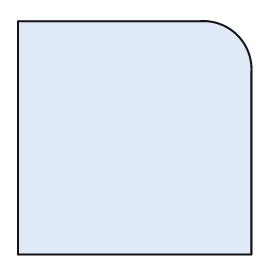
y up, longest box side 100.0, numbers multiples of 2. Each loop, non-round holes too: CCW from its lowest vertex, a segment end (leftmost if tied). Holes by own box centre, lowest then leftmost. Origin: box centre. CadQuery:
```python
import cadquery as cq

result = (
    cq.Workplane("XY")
    .moveTo(-50.0, -50.0)
    .lineTo(50.0, -50.0)
    .lineTo(50.0, 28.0)
    .threePointArc((44.0, 44.0), (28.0, 50.0))
    .lineTo(-50.0, 50.0)
    .close()
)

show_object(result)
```